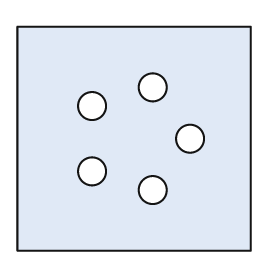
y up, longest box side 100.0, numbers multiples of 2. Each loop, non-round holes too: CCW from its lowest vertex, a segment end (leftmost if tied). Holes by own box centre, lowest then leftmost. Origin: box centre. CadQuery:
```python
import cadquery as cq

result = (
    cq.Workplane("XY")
    .moveTo(-50.0, -48.0)
    .lineTo(50.0, -48.0)
    .lineTo(50.0, 48.0)
    .lineTo(-50.0, 48.0)
    .close()
    .moveTo(8.0, -22.0)
    .circle(6.0)
    .moveTo(-18.0, -14.0)
    .circle(6.0)
    .moveTo(24.0, 0.0)
    .circle(6.0)
    .moveTo(-18.0, 14.0)
    .circle(6.0)
    .moveTo(8.0, 22.0)
    .circle(6.0)
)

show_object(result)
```